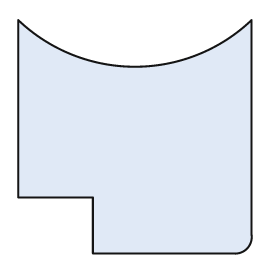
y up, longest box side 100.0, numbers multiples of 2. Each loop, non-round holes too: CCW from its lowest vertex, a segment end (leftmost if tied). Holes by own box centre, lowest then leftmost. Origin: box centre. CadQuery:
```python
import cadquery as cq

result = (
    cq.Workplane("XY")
    .moveTo(-18.0, -50.0)
    .lineTo(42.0, -50.0)
    .threePointArc((48.0, -48.0), (50.0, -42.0))
    .lineTo(50.0, 50.0)
    .threePointArc((0.0, 30.0), (-50.0, 50.0))
    .lineTo(-50.0, -26.0)
    .lineTo(-18.0, -26.0)
    .close()
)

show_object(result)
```